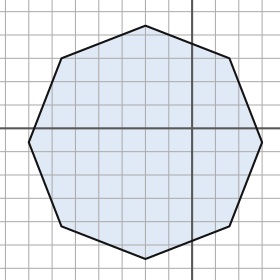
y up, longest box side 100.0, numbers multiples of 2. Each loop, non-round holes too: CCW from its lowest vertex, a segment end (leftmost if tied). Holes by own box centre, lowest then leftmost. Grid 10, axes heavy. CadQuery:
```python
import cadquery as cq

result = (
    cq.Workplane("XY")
    .moveTo(-20.0, -56.0)
    .lineTo(16.0, -42.0)
    .lineTo(30.0, -6.0)
    .lineTo(16.0, 30.0)
    .lineTo(-20.0, 44.0)
    .lineTo(-56.0, 30.0)
    .lineTo(-70.0, -6.0)
    .lineTo(-56.0, -42.0)
    .close()
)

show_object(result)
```